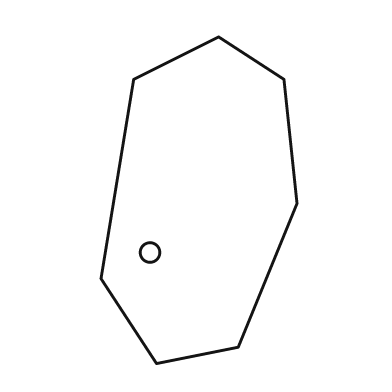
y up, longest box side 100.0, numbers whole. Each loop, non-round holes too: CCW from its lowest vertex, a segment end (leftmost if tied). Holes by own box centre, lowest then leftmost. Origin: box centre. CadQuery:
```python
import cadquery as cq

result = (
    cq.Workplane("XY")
    .moveTo(-13.0, -50.0)
    .lineTo(12.0, -45.0)
    .lineTo(30.0, -1.0)
    .lineTo(26.0, 37.0)
    .lineTo(6.0, 50.0)
    .lineTo(-20.0, 37.0)
    .lineTo(-30.0, -24.0)
    .close()
    .moveTo(-15.0, -16.0)
    .circle(3.0)
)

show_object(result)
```